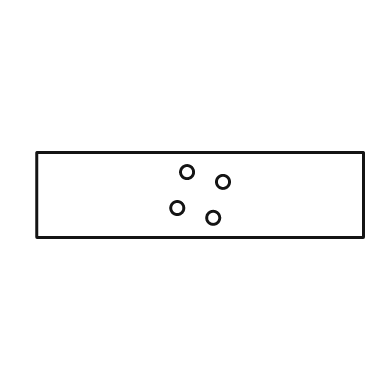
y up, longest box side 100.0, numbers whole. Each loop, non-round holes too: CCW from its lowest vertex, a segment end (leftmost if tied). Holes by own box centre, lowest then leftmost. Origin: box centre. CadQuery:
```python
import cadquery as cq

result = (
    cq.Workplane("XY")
    .moveTo(-50.0, -13.0)
    .lineTo(50.0, -13.0)
    .lineTo(50.0, 13.0)
    .lineTo(-50.0, 13.0)
    .close()
    .moveTo(4.0, -7.0)
    .circle(2.0)
    .moveTo(-7.0, -4.0)
    .circle(2.0)
    .moveTo(7.0, 4.0)
    .circle(2.0)
    .moveTo(-4.0, 7.0)
    .circle(2.0)
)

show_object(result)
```